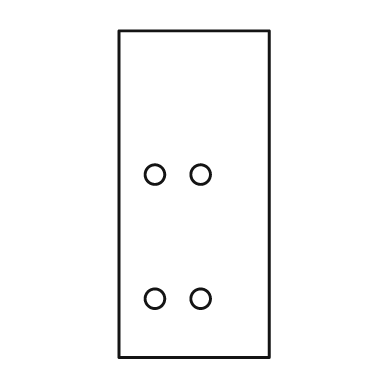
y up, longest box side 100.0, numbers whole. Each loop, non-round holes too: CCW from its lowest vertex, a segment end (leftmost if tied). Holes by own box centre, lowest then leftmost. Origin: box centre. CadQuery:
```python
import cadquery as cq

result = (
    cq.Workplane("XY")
    .moveTo(-23.0, -50.0)
    .lineTo(23.0, -50.0)
    .lineTo(23.0, 50.0)
    .lineTo(-23.0, 50.0)
    .close()
    .moveTo(-12.0, -32.0)
    .circle(3.0)
    .moveTo(2.0, -32.0)
    .circle(3.0)
    .moveTo(-12.0, 6.0)
    .circle(3.0)
    .moveTo(2.0, 6.0)
    .circle(3.0)
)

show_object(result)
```